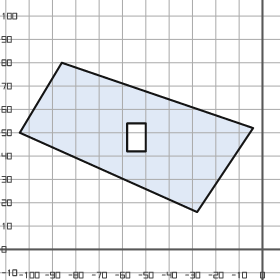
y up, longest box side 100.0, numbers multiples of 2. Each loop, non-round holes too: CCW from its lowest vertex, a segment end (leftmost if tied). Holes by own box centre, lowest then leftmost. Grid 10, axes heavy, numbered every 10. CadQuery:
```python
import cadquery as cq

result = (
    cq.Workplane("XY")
    .moveTo(-28.0, 16.0)
    .lineTo(-4.0, 52.0)
    .lineTo(-86.0, 80.0)
    .lineTo(-104.0, 50.0)
    .close()
    .moveTo(-58.0, 42.0)
    .lineTo(-50.0, 42.0)
    .lineTo(-50.0, 54.0)
    .lineTo(-58.0, 54.0)
    .close()
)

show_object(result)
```